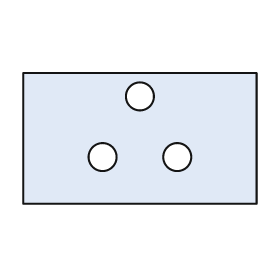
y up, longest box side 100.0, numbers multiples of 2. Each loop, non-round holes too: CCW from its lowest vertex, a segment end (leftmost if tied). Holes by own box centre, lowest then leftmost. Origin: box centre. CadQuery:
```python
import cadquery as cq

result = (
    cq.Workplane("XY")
    .moveTo(-50.0, -28.0)
    .lineTo(50.0, -28.0)
    .lineTo(50.0, 28.0)
    .lineTo(-50.0, 28.0)
    .close()
    .moveTo(-16.0, -8.0)
    .circle(6.0)
    .moveTo(16.0, -8.0)
    .circle(6.0)
    .moveTo(0.0, 18.0)
    .circle(6.0)
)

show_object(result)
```